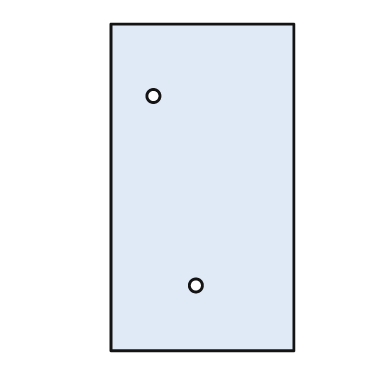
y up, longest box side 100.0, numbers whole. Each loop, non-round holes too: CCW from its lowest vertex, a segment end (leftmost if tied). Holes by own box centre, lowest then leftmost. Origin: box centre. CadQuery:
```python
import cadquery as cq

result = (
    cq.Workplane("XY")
    .moveTo(-28.0, -50.0)
    .lineTo(28.0, -50.0)
    .lineTo(28.0, 50.0)
    .lineTo(-28.0, 50.0)
    .close()
    .moveTo(-2.0, -30.0)
    .circle(2.0)
    .moveTo(-15.0, 28.0)
    .circle(2.0)
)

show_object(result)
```